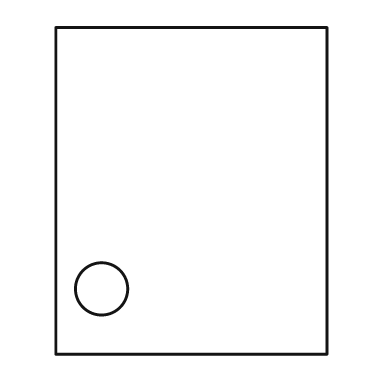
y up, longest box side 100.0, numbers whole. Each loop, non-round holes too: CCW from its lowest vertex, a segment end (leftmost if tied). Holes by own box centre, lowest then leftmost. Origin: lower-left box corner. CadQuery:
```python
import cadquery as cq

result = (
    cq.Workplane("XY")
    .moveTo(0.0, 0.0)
    .lineTo(83.0, 0.0)
    .lineTo(83.0, 100.0)
    .lineTo(0.0, 100.0)
    .close()
    .moveTo(14.0, 20.0)
    .circle(8.0)
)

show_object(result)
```